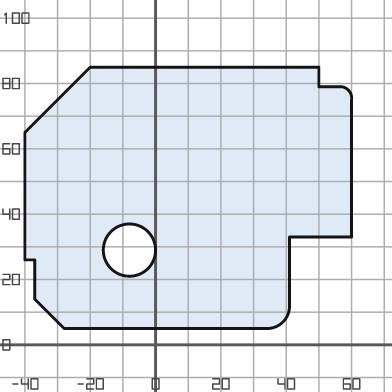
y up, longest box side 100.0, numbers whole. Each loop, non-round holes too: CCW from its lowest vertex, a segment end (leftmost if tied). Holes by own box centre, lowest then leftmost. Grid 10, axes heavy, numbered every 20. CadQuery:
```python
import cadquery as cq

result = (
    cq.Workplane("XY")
    .moveTo(-28.0, 5.0)
    .lineTo(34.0, 5.0)
    .threePointArc((39.0, 7.0), (41.0, 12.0))
    .lineTo(41.0, 33.0)
    .lineTo(60.0, 33.0)
    .lineTo(60.0, 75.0)
    .threePointArc((59.0, 78.0), (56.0, 79.0))
    .lineTo(50.0, 79.0)
    .lineTo(50.0, 85.0)
    .lineTo(-20.0, 85.0)
    .lineTo(-40.0, 65.0)
    .lineTo(-40.0, 26.0)
    .lineTo(-37.0, 26.0)
    .lineTo(-37.0, 14.0)
    .close()
    .moveTo(-8.0, 29.0)
    .circle(8.0)
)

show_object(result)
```